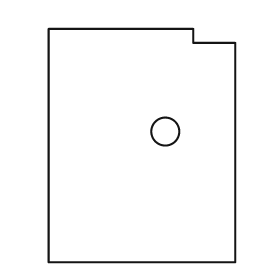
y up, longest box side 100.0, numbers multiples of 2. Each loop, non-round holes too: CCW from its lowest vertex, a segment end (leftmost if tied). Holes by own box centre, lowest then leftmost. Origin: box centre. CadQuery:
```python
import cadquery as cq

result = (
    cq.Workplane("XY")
    .moveTo(-40.0, -50.0)
    .lineTo(40.0, -50.0)
    .lineTo(40.0, 44.0)
    .lineTo(22.0, 44.0)
    .lineTo(22.0, 50.0)
    .lineTo(-40.0, 50.0)
    .close()
    .moveTo(10.0, 6.0)
    .circle(6.0)
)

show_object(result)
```